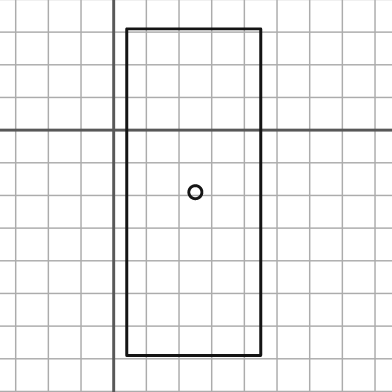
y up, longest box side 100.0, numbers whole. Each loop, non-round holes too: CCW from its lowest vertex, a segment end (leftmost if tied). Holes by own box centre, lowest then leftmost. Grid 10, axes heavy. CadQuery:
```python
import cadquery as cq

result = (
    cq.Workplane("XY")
    .moveTo(4.0, -69.0)
    .lineTo(45.0, -69.0)
    .lineTo(45.0, 31.0)
    .lineTo(4.0, 31.0)
    .close()
    .moveTo(25.0, -19.0)
    .circle(2.0)
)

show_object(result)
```